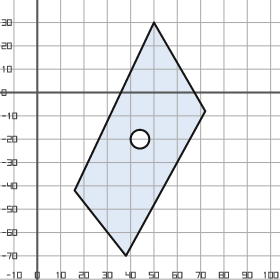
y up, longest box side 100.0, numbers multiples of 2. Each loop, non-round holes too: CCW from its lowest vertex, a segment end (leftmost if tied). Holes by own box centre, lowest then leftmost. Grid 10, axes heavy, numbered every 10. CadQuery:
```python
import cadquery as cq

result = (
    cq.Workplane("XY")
    .moveTo(38.0, -70.0)
    .lineTo(72.0, -8.0)
    .lineTo(50.0, 30.0)
    .lineTo(16.0, -42.0)
    .close()
    .moveTo(44.0, -20.0)
    .circle(4.0)
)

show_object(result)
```